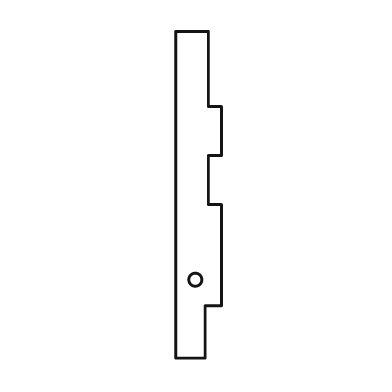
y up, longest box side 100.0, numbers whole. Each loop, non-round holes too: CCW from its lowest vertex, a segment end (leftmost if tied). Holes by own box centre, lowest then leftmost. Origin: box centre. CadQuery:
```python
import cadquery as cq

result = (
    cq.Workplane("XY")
    .moveTo(-7.0, -50.0)
    .lineTo(2.0, -50.0)
    .lineTo(2.0, -34.0)
    .lineTo(7.0, -34.0)
    .lineTo(7.0, -3.0)
    .lineTo(3.0, -3.0)
    .lineTo(3.0, 12.0)
    .lineTo(7.0, 12.0)
    .lineTo(7.0, 27.0)
    .lineTo(3.0, 27.0)
    .lineTo(3.0, 50.0)
    .lineTo(-7.0, 50.0)
    .close()
    .moveTo(-1.0, -26.0)
    .circle(2.0)
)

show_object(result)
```